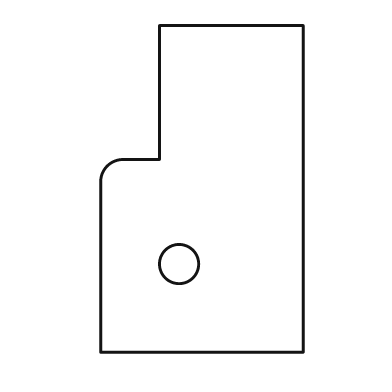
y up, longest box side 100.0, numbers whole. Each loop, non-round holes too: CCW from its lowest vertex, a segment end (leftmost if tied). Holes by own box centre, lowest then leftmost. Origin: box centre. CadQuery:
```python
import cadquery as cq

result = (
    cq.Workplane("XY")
    .moveTo(-31.0, -50.0)
    .lineTo(31.0, -50.0)
    .lineTo(31.0, 50.0)
    .lineTo(-13.0, 50.0)
    .lineTo(-13.0, 9.0)
    .lineTo(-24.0, 9.0)
    .threePointArc((-29.0, 7.0), (-31.0, 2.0))
    .close()
    .moveTo(-7.0, -23.0)
    .circle(6.0)
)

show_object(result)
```